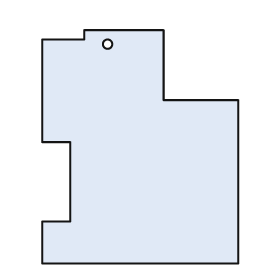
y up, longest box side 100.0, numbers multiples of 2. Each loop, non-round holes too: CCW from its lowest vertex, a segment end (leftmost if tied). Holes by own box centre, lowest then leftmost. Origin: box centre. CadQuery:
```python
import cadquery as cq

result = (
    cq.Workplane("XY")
    .moveTo(-42.0, -50.0)
    .lineTo(42.0, -50.0)
    .lineTo(42.0, 20.0)
    .lineTo(10.0, 20.0)
    .lineTo(10.0, 50.0)
    .lineTo(-24.0, 50.0)
    .lineTo(-24.0, 46.0)
    .lineTo(-42.0, 46.0)
    .lineTo(-42.0, 2.0)
    .lineTo(-30.0, 2.0)
    .lineTo(-30.0, -32.0)
    .lineTo(-42.0, -32.0)
    .close()
    .moveTo(-14.0, 44.0)
    .circle(2.0)
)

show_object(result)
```